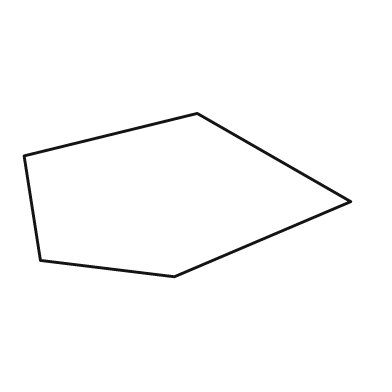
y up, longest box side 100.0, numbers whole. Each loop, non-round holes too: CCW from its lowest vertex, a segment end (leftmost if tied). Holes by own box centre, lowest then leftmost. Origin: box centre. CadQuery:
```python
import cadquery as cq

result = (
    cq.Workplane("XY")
    .moveTo(-4.0, -25.0)
    .lineTo(50.0, -2.0)
    .lineTo(3.0, 25.0)
    .lineTo(-50.0, 12.0)
    .lineTo(-45.0, -20.0)
    .close()
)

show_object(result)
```